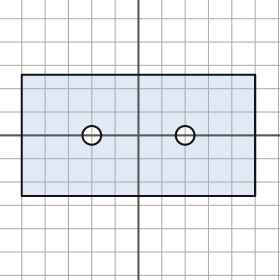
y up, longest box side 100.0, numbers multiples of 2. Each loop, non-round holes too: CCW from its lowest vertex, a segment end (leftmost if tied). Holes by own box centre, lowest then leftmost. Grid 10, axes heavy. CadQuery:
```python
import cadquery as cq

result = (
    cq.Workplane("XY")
    .moveTo(-50.0, -26.0)
    .lineTo(50.0, -26.0)
    .lineTo(50.0, 26.0)
    .lineTo(-50.0, 26.0)
    .close()
    .moveTo(-20.0, 0.0)
    .circle(4.0)
    .moveTo(20.0, 0.0)
    .circle(4.0)
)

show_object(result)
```